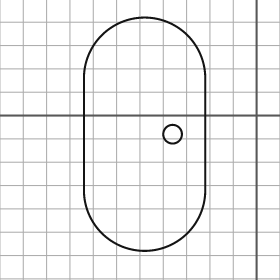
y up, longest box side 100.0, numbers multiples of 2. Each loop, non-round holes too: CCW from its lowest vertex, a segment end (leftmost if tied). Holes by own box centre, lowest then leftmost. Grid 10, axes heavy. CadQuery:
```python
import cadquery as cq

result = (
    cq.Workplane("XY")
    .moveTo(-74.0, -32.0)
    .threePointArc((-48.0, -58.0), (-22.0, -32.0))
    .lineTo(-22.0, 16.0)
    .threePointArc((-48.0, 42.0), (-74.0, 16.0))
    .close()
    .moveTo(-36.0, -8.0)
    .circle(4.0)
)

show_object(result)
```